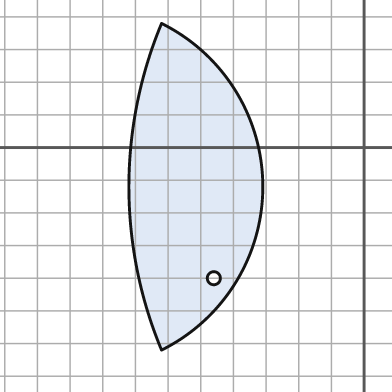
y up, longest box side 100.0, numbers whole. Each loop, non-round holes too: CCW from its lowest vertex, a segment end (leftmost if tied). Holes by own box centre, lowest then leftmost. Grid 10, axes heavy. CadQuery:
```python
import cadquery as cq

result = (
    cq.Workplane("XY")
    .moveTo(-62.0, -62.0)
    .threePointArc((-31.0, -12.0), (-62.0, 38.0))
    .threePointArc((-72.0, -12.0), (-62.0, -62.0))
    .close()
    .moveTo(-46.0, -40.0)
    .circle(2.0)
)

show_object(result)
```